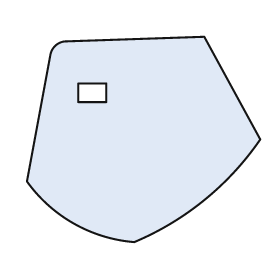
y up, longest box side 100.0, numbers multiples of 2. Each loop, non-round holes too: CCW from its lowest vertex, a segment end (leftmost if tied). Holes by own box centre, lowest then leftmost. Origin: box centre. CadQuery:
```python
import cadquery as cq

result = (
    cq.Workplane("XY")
    .moveTo(-4.0, -44.0)
    .threePointArc((26.0, -26.0), (50.0, 0.0))
    .lineTo(26.0, 44.0)
    .lineTo(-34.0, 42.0)
    .threePointArc((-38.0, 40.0), (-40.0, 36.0))
    .lineTo(-50.0, -18.0)
    .threePointArc((-30.0, -36.0), (-4.0, -44.0))
    .close()
    .moveTo(-28.0, 16.0)
    .lineTo(-16.0, 16.0)
    .lineTo(-16.0, 24.0)
    .lineTo(-28.0, 24.0)
    .close()
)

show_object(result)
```